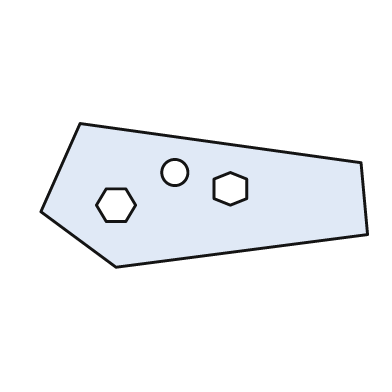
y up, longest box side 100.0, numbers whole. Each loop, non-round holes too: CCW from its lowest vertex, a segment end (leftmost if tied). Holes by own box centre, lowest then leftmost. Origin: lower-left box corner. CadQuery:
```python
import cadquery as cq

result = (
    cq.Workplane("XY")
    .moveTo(23.0, 0.0)
    .lineTo(100.0, 10.0)
    .lineTo(98.0, 32.0)
    .lineTo(12.0, 44.0)
    .lineTo(0.0, 17.0)
    .close()
    .moveTo(20.0, 14.0)
    .lineTo(26.0, 14.0)
    .lineTo(29.0, 19.0)
    .lineTo(26.0, 24.0)
    .lineTo(20.0, 24.0)
    .lineTo(17.0, 19.0)
    .close()
    .moveTo(58.0, 19.0)
    .lineTo(63.0, 21.0)
    .lineTo(63.0, 27.0)
    .lineTo(58.0, 29.0)
    .lineTo(53.0, 27.0)
    .lineTo(53.0, 21.0)
    .close()
    .moveTo(41.0, 29.0)
    .circle(4.0)
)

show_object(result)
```